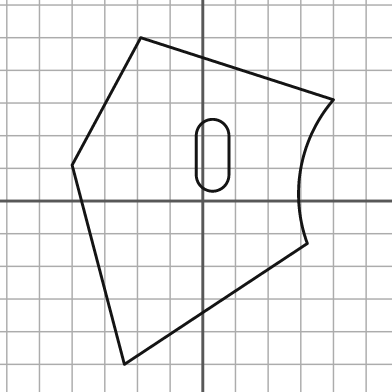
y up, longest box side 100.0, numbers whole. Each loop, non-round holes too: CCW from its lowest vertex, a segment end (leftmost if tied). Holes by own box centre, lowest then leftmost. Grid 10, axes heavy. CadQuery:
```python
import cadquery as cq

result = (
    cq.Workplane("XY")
    .moveTo(-24.0, -50.0)
    .lineTo(32.0, -13.0)
    .threePointArc((30.0, 10.0), (40.0, 31.0))
    .lineTo(-19.0, 50.0)
    .lineTo(-40.0, 11.0)
    .close()
    .moveTo(-2.0, 8.0)
    .threePointArc((3.0, 3.0), (8.0, 8.0))
    .lineTo(8.0, 20.0)
    .threePointArc((3.0, 25.0), (-2.0, 20.0))
    .close()
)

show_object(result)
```